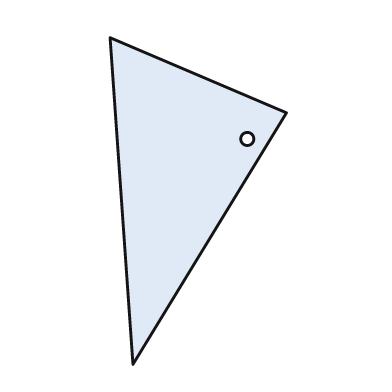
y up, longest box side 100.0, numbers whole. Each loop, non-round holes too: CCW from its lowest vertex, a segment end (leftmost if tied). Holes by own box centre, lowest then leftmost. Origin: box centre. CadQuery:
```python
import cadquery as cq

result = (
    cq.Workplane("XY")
    .moveTo(-20.0, -50.0)
    .lineTo(27.0, 27.0)
    .lineTo(-27.0, 50.0)
    .close()
    .moveTo(15.0, 19.0)
    .circle(2.0)
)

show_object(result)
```